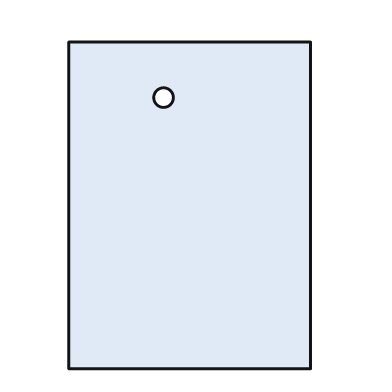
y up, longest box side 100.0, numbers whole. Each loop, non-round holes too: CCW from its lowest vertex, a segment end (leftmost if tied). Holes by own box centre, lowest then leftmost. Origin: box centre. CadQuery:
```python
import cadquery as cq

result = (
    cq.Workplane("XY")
    .moveTo(-37.0, -50.0)
    .lineTo(37.0, -50.0)
    .lineTo(37.0, 50.0)
    .lineTo(-37.0, 50.0)
    .close()
    .moveTo(-8.0, 33.0)
    .circle(3.0)
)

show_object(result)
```